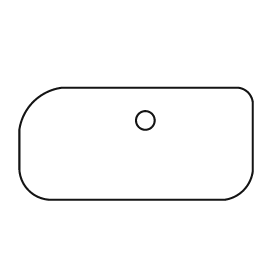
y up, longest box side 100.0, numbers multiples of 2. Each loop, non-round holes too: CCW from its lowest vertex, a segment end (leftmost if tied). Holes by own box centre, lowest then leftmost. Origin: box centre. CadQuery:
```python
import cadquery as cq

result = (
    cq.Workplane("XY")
    .moveTo(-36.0, -24.0)
    .lineTo(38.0, -24.0)
    .threePointArc((46.0, -20.0), (50.0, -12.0))
    .lineTo(50.0, 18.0)
    .threePointArc((48.0, 22.0), (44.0, 24.0))
    .lineTo(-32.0, 24.0)
    .threePointArc((-44.0, 18.0), (-50.0, 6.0))
    .lineTo(-50.0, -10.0)
    .threePointArc((-46.0, -20.0), (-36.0, -24.0))
    .close()
    .moveTo(4.0, 10.0)
    .circle(4.0)
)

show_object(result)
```